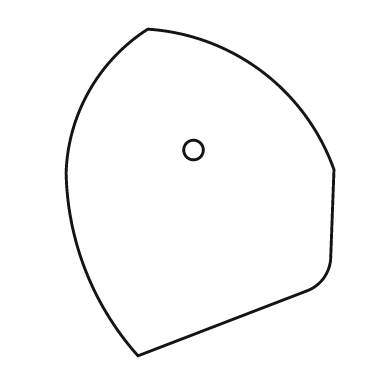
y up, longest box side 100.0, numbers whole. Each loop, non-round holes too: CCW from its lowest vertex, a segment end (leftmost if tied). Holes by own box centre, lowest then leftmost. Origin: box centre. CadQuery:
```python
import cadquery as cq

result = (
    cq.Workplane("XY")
    .moveTo(-19.0, -50.0)
    .lineTo(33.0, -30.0)
    .threePointArc((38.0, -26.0), (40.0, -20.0))
    .lineTo(41.0, 7.0)
    .threePointArc((19.0, 37.0), (-16.0, 50.0))
    .threePointArc((-34.0, 31.0), (-41.0, 6.0))
    .threePointArc((-35.0, -24.0), (-19.0, -50.0))
    .close()
    .moveTo(-2.0, 13.0)
    .circle(3.0)
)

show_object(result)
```